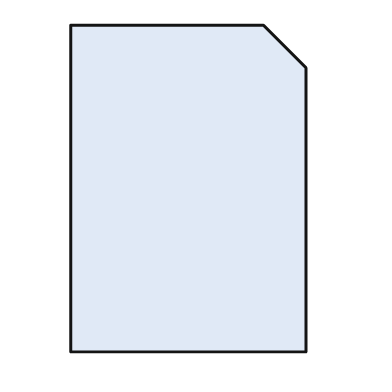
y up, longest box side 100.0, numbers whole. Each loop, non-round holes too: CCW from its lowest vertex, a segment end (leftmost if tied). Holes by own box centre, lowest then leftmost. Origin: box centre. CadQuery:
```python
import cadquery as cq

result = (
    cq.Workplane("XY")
    .moveTo(-36.0, -50.0)
    .lineTo(36.0, -50.0)
    .lineTo(36.0, 37.0)
    .lineTo(23.0, 50.0)
    .lineTo(-36.0, 50.0)
    .close()
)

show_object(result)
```